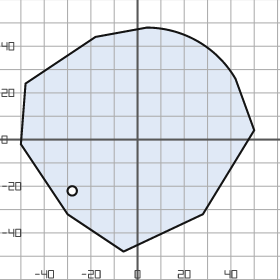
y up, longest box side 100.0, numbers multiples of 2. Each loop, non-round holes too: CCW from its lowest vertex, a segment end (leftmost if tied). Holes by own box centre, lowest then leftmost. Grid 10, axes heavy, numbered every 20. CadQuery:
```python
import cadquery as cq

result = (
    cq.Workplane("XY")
    .moveTo(-6.0, -48.0)
    .lineTo(28.0, -32.0)
    .lineTo(50.0, 4.0)
    .lineTo(42.0, 26.0)
    .threePointArc((26.0, 42.0), (4.0, 48.0))
    .lineTo(-18.0, 44.0)
    .lineTo(-48.0, 24.0)
    .lineTo(-50.0, -2.0)
    .lineTo(-30.0, -32.0)
    .close()
    .moveTo(-28.0, -22.0)
    .circle(2.0)
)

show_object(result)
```